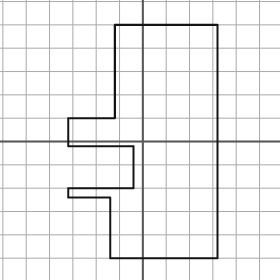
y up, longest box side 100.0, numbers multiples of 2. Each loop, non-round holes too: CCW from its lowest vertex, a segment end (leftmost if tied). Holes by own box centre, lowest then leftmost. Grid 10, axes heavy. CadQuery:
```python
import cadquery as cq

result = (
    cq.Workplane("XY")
    .moveTo(-14.0, -50.0)
    .lineTo(32.0, -50.0)
    .lineTo(32.0, 50.0)
    .lineTo(-12.0, 50.0)
    .lineTo(-12.0, 10.0)
    .lineTo(-32.0, 10.0)
    .lineTo(-32.0, -2.0)
    .lineTo(-4.0, -2.0)
    .lineTo(-4.0, -20.0)
    .lineTo(-32.0, -20.0)
    .lineTo(-32.0, -24.0)
    .lineTo(-14.0, -24.0)
    .close()
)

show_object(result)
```